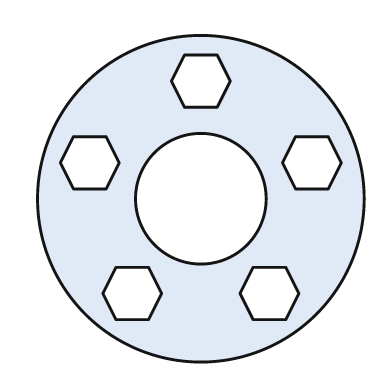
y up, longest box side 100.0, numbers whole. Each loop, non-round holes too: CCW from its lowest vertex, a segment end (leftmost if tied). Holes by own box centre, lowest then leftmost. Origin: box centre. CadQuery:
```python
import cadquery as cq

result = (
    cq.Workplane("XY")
    .moveTo(0.0, 0.0)
    .circle(50.0)
    .moveTo(-26.0, -37.0)
    .lineTo(-16.0, -37.0)
    .lineTo(-12.0, -29.0)
    .lineTo(-16.0, -21.0)
    .lineTo(-26.0, -21.0)
    .lineTo(-30.0, -29.0)
    .close()
    .moveTo(16.0, -37.0)
    .lineTo(26.0, -37.0)
    .lineTo(30.0, -29.0)
    .lineTo(26.0, -21.0)
    .lineTo(16.0, -21.0)
    .lineTo(12.0, -29.0)
    .close()
    .moveTo(0.0, 0.0)
    .circle(20.0)
    .moveTo(-39.0, 3.0)
    .lineTo(-29.0, 3.0)
    .lineTo(-25.0, 11.0)
    .lineTo(-29.0, 19.0)
    .lineTo(-39.0, 19.0)
    .lineTo(-43.0, 11.0)
    .close()
    .moveTo(29.0, 3.0)
    .lineTo(39.0, 3.0)
    .lineTo(43.0, 11.0)
    .lineTo(39.0, 19.0)
    .lineTo(29.0, 19.0)
    .lineTo(25.0, 11.0)
    .close()
    .moveTo(-5.0, 28.0)
    .lineTo(5.0, 28.0)
    .lineTo(9.0, 36.0)
    .lineTo(5.0, 44.0)
    .lineTo(-5.0, 44.0)
    .lineTo(-9.0, 36.0)
    .close()
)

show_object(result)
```